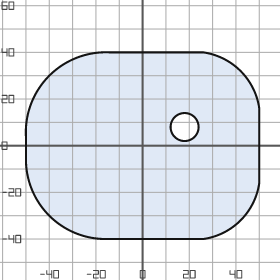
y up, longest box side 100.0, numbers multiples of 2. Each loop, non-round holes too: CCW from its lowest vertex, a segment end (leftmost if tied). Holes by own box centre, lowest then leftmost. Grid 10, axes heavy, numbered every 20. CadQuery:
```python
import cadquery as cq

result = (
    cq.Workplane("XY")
    .moveTo(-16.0, -40.0)
    .lineTo(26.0, -40.0)
    .threePointArc((42.0, -32.0), (50.0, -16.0))
    .lineTo(50.0, 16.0)
    .threePointArc((42.0, 32.0), (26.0, 40.0))
    .lineTo(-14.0, 40.0)
    .threePointArc((-40.0, 30.0), (-50.0, 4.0))
    .lineTo(-50.0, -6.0)
    .threePointArc((-40.0, -30.0), (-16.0, -40.0))
    .close()
    .moveTo(18.0, 8.0)
    .circle(6.0)
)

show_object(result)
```